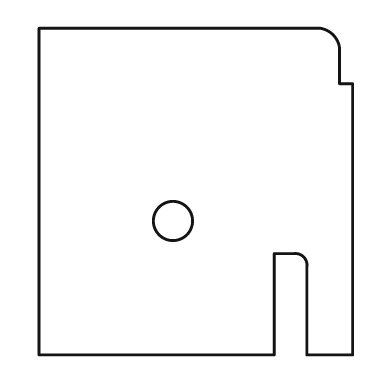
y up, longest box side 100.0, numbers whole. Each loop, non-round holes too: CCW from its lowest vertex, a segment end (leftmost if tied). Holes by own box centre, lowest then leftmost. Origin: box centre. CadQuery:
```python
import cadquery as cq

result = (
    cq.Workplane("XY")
    .moveTo(-48.0, -50.0)
    .lineTo(24.0, -50.0)
    .lineTo(24.0, -19.0)
    .lineTo(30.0, -19.0)
    .threePointArc((33.0, -20.0), (34.0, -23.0))
    .lineTo(34.0, -50.0)
    .lineTo(48.0, -50.0)
    .lineTo(48.0, 33.0)
    .lineTo(44.0, 33.0)
    .lineTo(44.0, 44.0)
    .threePointArc((42.0, 48.0), (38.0, 50.0))
    .lineTo(-48.0, 50.0)
    .close()
    .moveTo(-7.0, -9.0)
    .circle(6.0)
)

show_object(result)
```